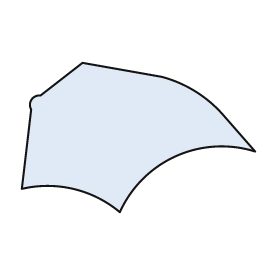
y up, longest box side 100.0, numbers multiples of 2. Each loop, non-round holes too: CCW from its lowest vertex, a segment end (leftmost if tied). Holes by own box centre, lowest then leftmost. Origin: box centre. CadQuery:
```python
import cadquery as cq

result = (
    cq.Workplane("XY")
    .moveTo(-8.0, -32.0)
    .threePointArc((16.0, -8.0), (50.0, -6.0))
    .lineTo(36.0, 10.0)
    .threePointArc((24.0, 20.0), (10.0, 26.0))
    .lineTo(-24.0, 32.0)
    .lineTo(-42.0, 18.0)
    .threePointArc((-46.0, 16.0), (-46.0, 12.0))
    .lineTo(-50.0, -22.0)
    .threePointArc((-28.0, -22.0), (-8.0, -32.0))
    .close()
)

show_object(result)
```